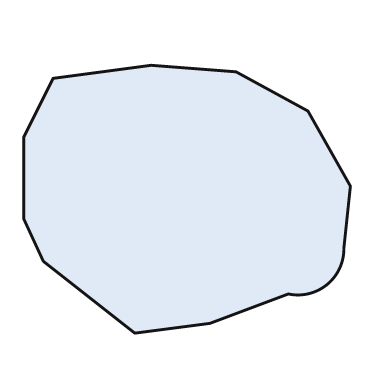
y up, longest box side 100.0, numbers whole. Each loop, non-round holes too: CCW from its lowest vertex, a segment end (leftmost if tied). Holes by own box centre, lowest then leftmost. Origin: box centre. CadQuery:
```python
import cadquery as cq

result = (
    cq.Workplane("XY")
    .moveTo(-16.0, -41.0)
    .lineTo(7.0, -38.0)
    .lineTo(31.0, -29.0)
    .threePointArc((43.0, -26.0), (48.0, -15.0))
    .lineTo(50.0, 4.0)
    .lineTo(37.0, 27.0)
    .lineTo(15.0, 39.0)
    .lineTo(-11.0, 41.0)
    .lineTo(-41.0, 37.0)
    .lineTo(-50.0, 19.0)
    .lineTo(-50.0, -6.0)
    .lineTo(-44.0, -19.0)
    .close()
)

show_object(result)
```